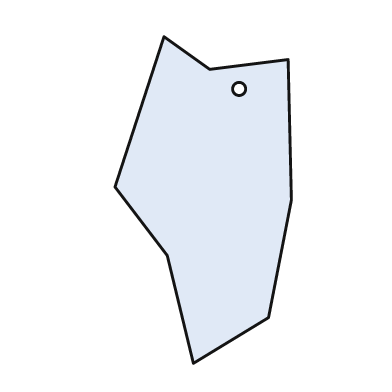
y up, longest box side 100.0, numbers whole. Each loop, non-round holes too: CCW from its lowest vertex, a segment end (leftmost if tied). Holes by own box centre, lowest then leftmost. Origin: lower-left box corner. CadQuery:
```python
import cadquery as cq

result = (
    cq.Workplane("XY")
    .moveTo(24.0, 0.0)
    .lineTo(47.0, 14.0)
    .lineTo(54.0, 50.0)
    .lineTo(53.0, 93.0)
    .lineTo(29.0, 90.0)
    .lineTo(15.0, 100.0)
    .lineTo(0.0, 54.0)
    .lineTo(16.0, 33.0)
    .close()
    .moveTo(38.0, 84.0)
    .circle(2.0)
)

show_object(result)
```